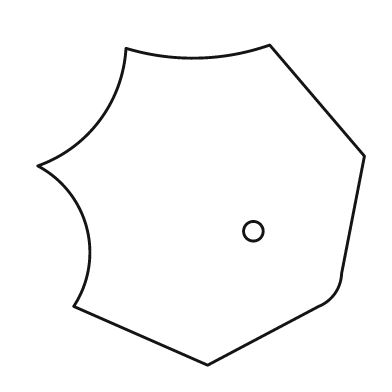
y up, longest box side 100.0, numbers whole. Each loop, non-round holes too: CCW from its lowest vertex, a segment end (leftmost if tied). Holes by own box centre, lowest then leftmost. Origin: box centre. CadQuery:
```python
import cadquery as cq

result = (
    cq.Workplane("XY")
    .moveTo(2.0, -49.0)
    .lineTo(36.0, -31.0)
    .threePointArc((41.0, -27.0), (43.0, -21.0))
    .lineTo(50.0, 15.0)
    .lineTo(21.0, 49.0)
    .threePointArc((-1.0, 45.0), (-23.0, 48.0))
    .threePointArc((-31.0, 26.0), (-50.0, 12.0))
    .threePointArc((-35.0, -7.0), (-39.0, -31.0))
    .close()
    .moveTo(16.0, -8.0)
    .circle(3.0)
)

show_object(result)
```